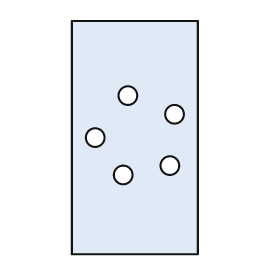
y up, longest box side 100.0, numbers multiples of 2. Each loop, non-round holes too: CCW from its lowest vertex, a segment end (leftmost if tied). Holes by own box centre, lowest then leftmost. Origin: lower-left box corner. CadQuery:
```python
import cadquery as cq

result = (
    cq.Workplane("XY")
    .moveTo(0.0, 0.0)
    .lineTo(54.0, 0.0)
    .lineTo(54.0, 100.0)
    .lineTo(0.0, 100.0)
    .close()
    .moveTo(22.0, 34.0)
    .circle(4.0)
    .moveTo(42.0, 38.0)
    .circle(4.0)
    .moveTo(10.0, 50.0)
    .circle(4.0)
    .moveTo(44.0, 60.0)
    .circle(4.0)
    .moveTo(24.0, 68.0)
    .circle(4.0)
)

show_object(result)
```